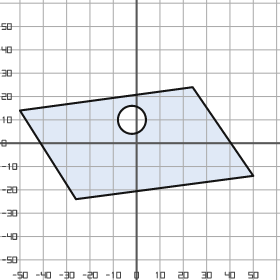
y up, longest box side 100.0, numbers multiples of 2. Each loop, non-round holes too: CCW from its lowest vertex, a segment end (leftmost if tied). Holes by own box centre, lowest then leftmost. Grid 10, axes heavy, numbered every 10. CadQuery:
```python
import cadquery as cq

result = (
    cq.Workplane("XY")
    .moveTo(-26.0, -24.0)
    .lineTo(50.0, -14.0)
    .lineTo(24.0, 24.0)
    .lineTo(-50.0, 14.0)
    .close()
    .moveTo(-2.0, 10.0)
    .circle(6.0)
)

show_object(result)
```